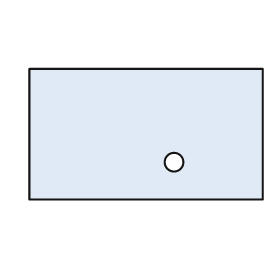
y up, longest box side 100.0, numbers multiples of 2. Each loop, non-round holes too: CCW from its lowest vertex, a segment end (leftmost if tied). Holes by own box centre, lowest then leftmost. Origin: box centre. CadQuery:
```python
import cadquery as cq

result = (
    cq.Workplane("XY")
    .moveTo(-50.0, -28.0)
    .lineTo(50.0, -28.0)
    .lineTo(50.0, 28.0)
    .lineTo(-50.0, 28.0)
    .close()
    .moveTo(12.0, -12.0)
    .circle(4.0)
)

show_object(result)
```